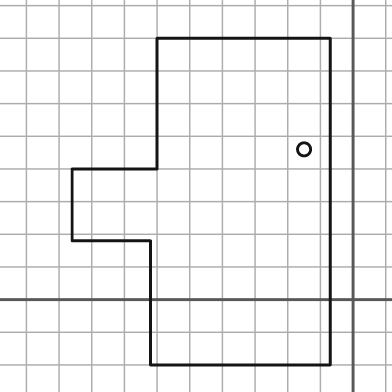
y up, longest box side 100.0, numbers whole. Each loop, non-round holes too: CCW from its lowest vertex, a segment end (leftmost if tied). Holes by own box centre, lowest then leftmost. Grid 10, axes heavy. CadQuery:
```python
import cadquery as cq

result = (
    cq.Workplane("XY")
    .moveTo(-62.0, -20.0)
    .lineTo(-7.0, -20.0)
    .lineTo(-7.0, 80.0)
    .lineTo(-60.0, 80.0)
    .lineTo(-60.0, 40.0)
    .lineTo(-86.0, 40.0)
    .lineTo(-86.0, 18.0)
    .lineTo(-62.0, 18.0)
    .close()
    .moveTo(-15.0, 46.0)
    .circle(2.0)
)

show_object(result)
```